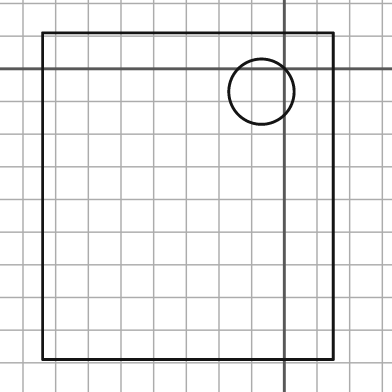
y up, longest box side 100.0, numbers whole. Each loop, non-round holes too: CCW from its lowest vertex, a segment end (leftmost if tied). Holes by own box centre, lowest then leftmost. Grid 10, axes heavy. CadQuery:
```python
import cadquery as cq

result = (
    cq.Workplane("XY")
    .moveTo(-74.0, -89.0)
    .lineTo(15.0, -89.0)
    .lineTo(15.0, 11.0)
    .lineTo(-74.0, 11.0)
    .close()
    .moveTo(-7.0, -7.0)
    .circle(10.0)
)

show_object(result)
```